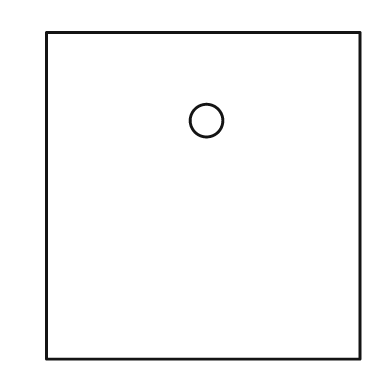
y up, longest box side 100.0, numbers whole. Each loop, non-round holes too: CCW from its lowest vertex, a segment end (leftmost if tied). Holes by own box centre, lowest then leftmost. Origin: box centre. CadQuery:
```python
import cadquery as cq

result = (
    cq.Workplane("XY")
    .moveTo(-48.0, -50.0)
    .lineTo(48.0, -50.0)
    .lineTo(48.0, 50.0)
    .lineTo(-48.0, 50.0)
    .close()
    .moveTo(1.0, 23.0)
    .circle(5.0)
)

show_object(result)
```